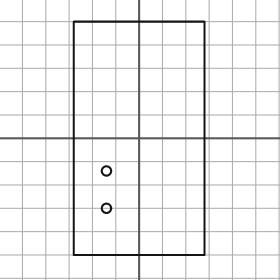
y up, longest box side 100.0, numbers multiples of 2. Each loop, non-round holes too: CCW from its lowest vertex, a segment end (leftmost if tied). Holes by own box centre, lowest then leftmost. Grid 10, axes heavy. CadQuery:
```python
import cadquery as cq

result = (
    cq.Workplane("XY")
    .moveTo(-28.0, -50.0)
    .lineTo(28.0, -50.0)
    .lineTo(28.0, 50.0)
    .lineTo(-28.0, 50.0)
    .close()
    .moveTo(-14.0, -30.0)
    .circle(2.0)
    .moveTo(-14.0, -14.0)
    .circle(2.0)
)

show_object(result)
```